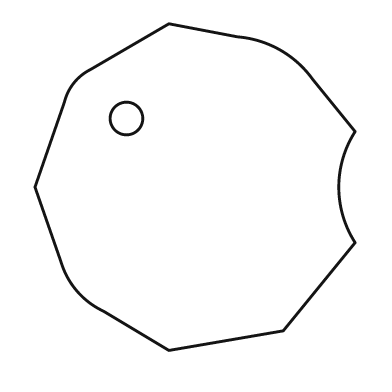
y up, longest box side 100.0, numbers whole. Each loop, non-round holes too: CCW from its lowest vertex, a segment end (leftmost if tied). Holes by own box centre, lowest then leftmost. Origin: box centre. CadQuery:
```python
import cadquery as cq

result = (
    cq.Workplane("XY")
    .moveTo(-8.0, -50.0)
    .lineTo(27.0, -44.0)
    .lineTo(49.0, -17.0)
    .threePointArc((44.0, 0.0), (49.0, 17.0))
    .lineTo(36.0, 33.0)
    .threePointArc((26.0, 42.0), (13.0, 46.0))
    .lineTo(-8.0, 50.0)
    .lineTo(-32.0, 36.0)
    .threePointArc((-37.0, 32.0), (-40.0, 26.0))
    .lineTo(-49.0, 0.0)
    .lineTo(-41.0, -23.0)
    .threePointArc((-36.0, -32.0), (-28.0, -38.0))
    .close()
    .moveTo(-21.0, 21.0)
    .circle(5.0)
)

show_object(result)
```